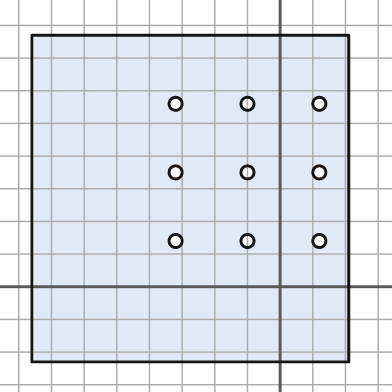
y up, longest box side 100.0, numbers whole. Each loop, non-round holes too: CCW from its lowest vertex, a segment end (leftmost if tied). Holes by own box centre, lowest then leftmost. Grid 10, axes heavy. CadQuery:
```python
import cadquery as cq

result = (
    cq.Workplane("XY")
    .moveTo(-76.0, -23.0)
    .lineTo(21.0, -23.0)
    .lineTo(21.0, 77.0)
    .lineTo(-76.0, 77.0)
    .close()
    .moveTo(-32.0, 14.0)
    .circle(2.0)
    .moveTo(-10.0, 14.0)
    .circle(2.0)
    .moveTo(12.0, 14.0)
    .circle(2.0)
    .moveTo(-32.0, 35.0)
    .circle(2.0)
    .moveTo(-10.0, 35.0)
    .circle(2.0)
    .moveTo(12.0, 35.0)
    .circle(2.0)
    .moveTo(-32.0, 56.0)
    .circle(2.0)
    .moveTo(-10.0, 56.0)
    .circle(2.0)
    .moveTo(12.0, 56.0)
    .circle(2.0)
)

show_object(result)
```